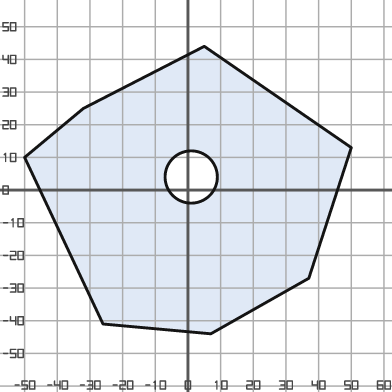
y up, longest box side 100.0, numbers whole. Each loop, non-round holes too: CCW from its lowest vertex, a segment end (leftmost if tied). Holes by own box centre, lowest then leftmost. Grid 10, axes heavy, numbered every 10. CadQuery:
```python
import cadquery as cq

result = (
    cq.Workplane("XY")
    .moveTo(7.0, -44.0)
    .lineTo(37.0, -27.0)
    .lineTo(50.0, 13.0)
    .lineTo(5.0, 44.0)
    .lineTo(-32.0, 25.0)
    .lineTo(-50.0, 10.0)
    .lineTo(-26.0, -41.0)
    .close()
    .moveTo(1.0, 4.0)
    .circle(8.0)
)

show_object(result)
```